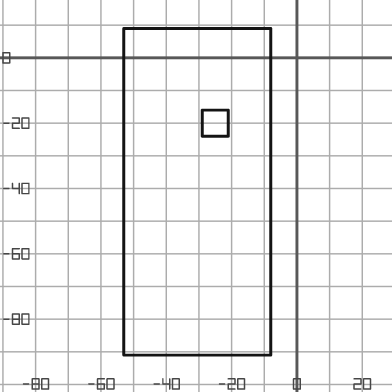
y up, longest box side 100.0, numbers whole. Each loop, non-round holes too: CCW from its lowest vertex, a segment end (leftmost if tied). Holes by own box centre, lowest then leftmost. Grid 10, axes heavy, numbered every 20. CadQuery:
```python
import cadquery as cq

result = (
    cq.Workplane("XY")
    .moveTo(-53.0, -91.0)
    .lineTo(-8.0, -91.0)
    .lineTo(-8.0, 9.0)
    .lineTo(-53.0, 9.0)
    .close()
    .moveTo(-29.0, -24.0)
    .lineTo(-21.0, -24.0)
    .lineTo(-21.0, -16.0)
    .lineTo(-29.0, -16.0)
    .close()
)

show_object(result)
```